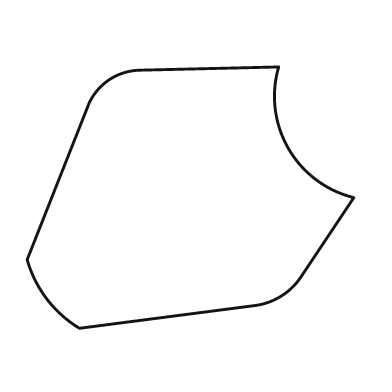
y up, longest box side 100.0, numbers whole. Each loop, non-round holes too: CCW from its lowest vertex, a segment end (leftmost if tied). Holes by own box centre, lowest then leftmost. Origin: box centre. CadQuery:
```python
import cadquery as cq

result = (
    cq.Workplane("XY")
    .moveTo(-34.0, -40.0)
    .lineTo(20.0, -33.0)
    .threePointArc((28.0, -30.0), (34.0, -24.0))
    .lineTo(50.0, 0.0)
    .threePointArc((30.0, 15.0), (27.0, 40.0))
    .lineTo(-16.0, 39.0)
    .threePointArc((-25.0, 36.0), (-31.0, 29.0))
    .lineTo(-50.0, -19.0)
    .threePointArc((-44.0, -31.0), (-34.0, -40.0))
    .close()
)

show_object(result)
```